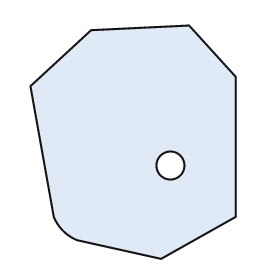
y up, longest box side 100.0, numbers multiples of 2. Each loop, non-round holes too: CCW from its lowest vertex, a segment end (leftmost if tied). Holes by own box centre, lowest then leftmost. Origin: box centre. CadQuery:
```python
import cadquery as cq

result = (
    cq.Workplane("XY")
    .moveTo(12.0, -50.0)
    .lineTo(44.0, -32.0)
    .lineTo(44.0, 28.0)
    .lineTo(24.0, 50.0)
    .lineTo(-18.0, 48.0)
    .lineTo(-44.0, 24.0)
    .lineTo(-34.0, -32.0)
    .threePointArc((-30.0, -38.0), (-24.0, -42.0))
    .close()
    .moveTo(16.0, -10.0)
    .circle(6.0)
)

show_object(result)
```